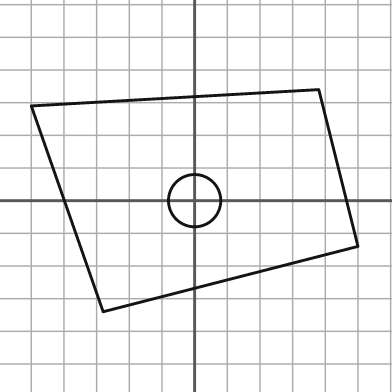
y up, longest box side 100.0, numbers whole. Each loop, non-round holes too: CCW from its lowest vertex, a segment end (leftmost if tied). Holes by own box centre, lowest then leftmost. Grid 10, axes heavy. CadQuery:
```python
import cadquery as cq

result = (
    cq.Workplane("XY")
    .moveTo(-28.0, -34.0)
    .lineTo(50.0, -14.0)
    .lineTo(38.0, 34.0)
    .lineTo(-50.0, 29.0)
    .close()
    .moveTo(0.0, 0.0)
    .circle(8.0)
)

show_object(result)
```